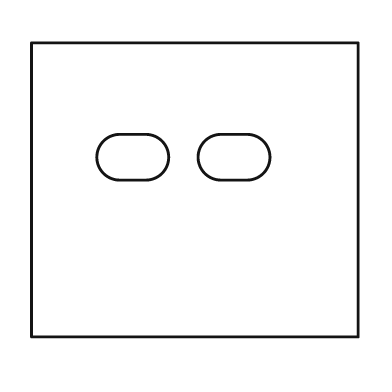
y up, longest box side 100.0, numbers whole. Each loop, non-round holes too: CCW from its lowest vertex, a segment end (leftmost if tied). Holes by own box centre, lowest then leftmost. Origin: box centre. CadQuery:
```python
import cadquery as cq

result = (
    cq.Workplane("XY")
    .moveTo(-50.0, -45.0)
    .lineTo(50.0, -45.0)
    .lineTo(50.0, 45.0)
    .lineTo(-50.0, 45.0)
    .close()
    .moveTo(-23.0, 3.0)
    .lineTo(-15.0, 3.0)
    .threePointArc((-8.0, 10.0), (-15.0, 17.0))
    .lineTo(-23.0, 17.0)
    .threePointArc((-30.0, 10.0), (-23.0, 3.0))
    .close()
    .moveTo(8.0, 3.0)
    .lineTo(16.0, 3.0)
    .threePointArc((23.0, 10.0), (16.0, 17.0))
    .lineTo(8.0, 17.0)
    .threePointArc((1.0, 10.0), (8.0, 3.0))
    .close()
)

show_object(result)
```